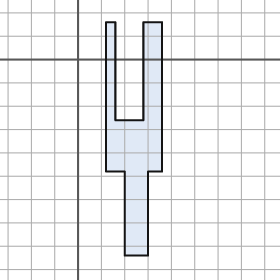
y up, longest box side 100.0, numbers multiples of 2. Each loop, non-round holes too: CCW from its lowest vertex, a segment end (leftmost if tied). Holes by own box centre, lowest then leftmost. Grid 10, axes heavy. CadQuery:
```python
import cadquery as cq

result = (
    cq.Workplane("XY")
    .moveTo(20.0, -84.0)
    .lineTo(30.0, -84.0)
    .lineTo(30.0, -48.0)
    .lineTo(36.0, -48.0)
    .lineTo(36.0, 16.0)
    .lineTo(28.0, 16.0)
    .lineTo(28.0, -26.0)
    .lineTo(16.0, -26.0)
    .lineTo(16.0, 16.0)
    .lineTo(12.0, 16.0)
    .lineTo(12.0, -48.0)
    .lineTo(20.0, -48.0)
    .close()
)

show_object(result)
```